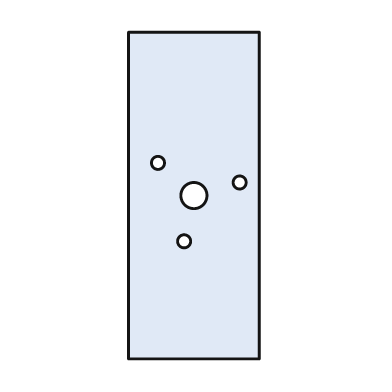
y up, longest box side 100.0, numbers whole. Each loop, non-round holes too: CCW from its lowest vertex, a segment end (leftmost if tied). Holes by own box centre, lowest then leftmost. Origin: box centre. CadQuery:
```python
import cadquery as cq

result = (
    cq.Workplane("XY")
    .moveTo(-20.0, -50.0)
    .lineTo(20.0, -50.0)
    .lineTo(20.0, 50.0)
    .lineTo(-20.0, 50.0)
    .close()
    .moveTo(-3.0, -14.0)
    .circle(2.0)
    .moveTo(0.0, 0.0)
    .circle(4.0)
    .moveTo(14.0, 4.0)
    .circle(2.0)
    .moveTo(-11.0, 10.0)
    .circle(2.0)
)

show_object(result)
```